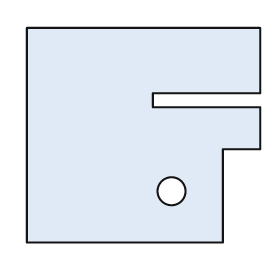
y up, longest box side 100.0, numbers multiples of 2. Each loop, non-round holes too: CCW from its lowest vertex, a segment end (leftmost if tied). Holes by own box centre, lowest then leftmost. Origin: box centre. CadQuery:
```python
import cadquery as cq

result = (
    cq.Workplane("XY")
    .moveTo(-50.0, -46.0)
    .lineTo(34.0, -46.0)
    .lineTo(34.0, -6.0)
    .lineTo(50.0, -6.0)
    .lineTo(50.0, 12.0)
    .lineTo(4.0, 12.0)
    .lineTo(4.0, 18.0)
    .lineTo(50.0, 18.0)
    .lineTo(50.0, 46.0)
    .lineTo(-50.0, 46.0)
    .close()
    .moveTo(12.0, -24.0)
    .circle(6.0)
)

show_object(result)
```